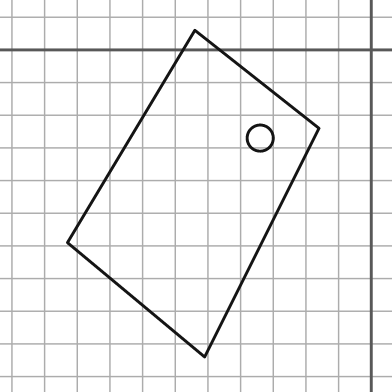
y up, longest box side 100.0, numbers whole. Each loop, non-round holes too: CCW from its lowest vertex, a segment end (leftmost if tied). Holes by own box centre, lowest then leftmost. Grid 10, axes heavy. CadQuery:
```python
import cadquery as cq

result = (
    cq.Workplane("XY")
    .moveTo(-51.0, -94.0)
    .lineTo(-16.0, -24.0)
    .lineTo(-54.0, 6.0)
    .lineTo(-93.0, -59.0)
    .close()
    .moveTo(-34.0, -27.0)
    .circle(4.0)
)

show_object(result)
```